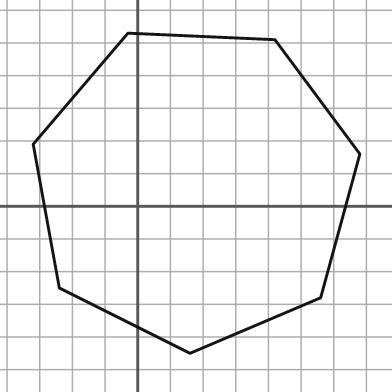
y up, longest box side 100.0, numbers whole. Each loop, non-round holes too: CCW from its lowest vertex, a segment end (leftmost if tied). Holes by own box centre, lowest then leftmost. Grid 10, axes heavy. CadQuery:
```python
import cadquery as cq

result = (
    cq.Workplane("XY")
    .moveTo(16.0, -45.0)
    .lineTo(56.0, -28.0)
    .lineTo(68.0, 16.0)
    .lineTo(42.0, 51.0)
    .lineTo(-3.0, 53.0)
    .lineTo(-32.0, 19.0)
    .lineTo(-24.0, -25.0)
    .close()
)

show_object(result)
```